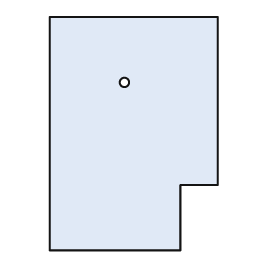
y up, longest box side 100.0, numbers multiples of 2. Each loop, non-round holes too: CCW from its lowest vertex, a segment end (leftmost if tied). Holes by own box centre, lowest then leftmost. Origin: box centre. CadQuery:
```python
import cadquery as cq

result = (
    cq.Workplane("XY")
    .moveTo(-36.0, -50.0)
    .lineTo(20.0, -50.0)
    .lineTo(20.0, -22.0)
    .lineTo(36.0, -22.0)
    .lineTo(36.0, 50.0)
    .lineTo(-36.0, 50.0)
    .close()
    .moveTo(-4.0, 22.0)
    .circle(2.0)
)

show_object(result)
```